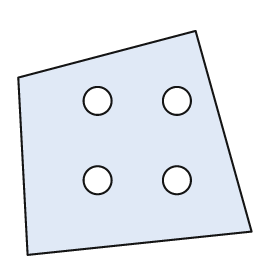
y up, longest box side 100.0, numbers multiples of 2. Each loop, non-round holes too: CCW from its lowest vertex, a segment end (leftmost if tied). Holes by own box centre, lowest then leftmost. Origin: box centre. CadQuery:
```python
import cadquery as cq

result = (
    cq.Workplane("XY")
    .moveTo(-46.0, -48.0)
    .lineTo(50.0, -38.0)
    .lineTo(26.0, 48.0)
    .lineTo(-50.0, 28.0)
    .close()
    .moveTo(-16.0, -16.0)
    .circle(6.0)
    .moveTo(18.0, -16.0)
    .circle(6.0)
    .moveTo(-16.0, 18.0)
    .circle(6.0)
    .moveTo(18.0, 18.0)
    .circle(6.0)
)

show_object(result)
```